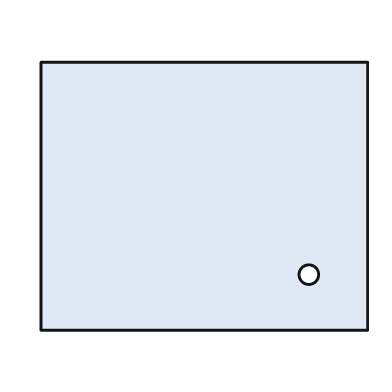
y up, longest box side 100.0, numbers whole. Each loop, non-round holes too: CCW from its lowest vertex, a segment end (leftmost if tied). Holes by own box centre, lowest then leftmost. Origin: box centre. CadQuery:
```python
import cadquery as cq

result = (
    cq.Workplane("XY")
    .moveTo(-50.0, -41.0)
    .lineTo(50.0, -41.0)
    .lineTo(50.0, 41.0)
    .lineTo(-50.0, 41.0)
    .close()
    .moveTo(32.0, -24.0)
    .circle(3.0)
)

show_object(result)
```